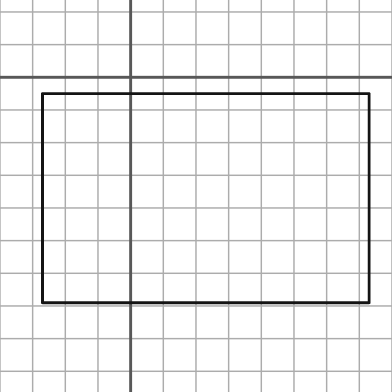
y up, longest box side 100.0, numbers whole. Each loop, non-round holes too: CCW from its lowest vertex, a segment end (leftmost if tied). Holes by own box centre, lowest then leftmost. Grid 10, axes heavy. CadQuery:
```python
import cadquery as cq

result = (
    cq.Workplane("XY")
    .moveTo(-27.0, -69.0)
    .lineTo(73.0, -69.0)
    .lineTo(73.0, -5.0)
    .lineTo(-27.0, -5.0)
    .close()
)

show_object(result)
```